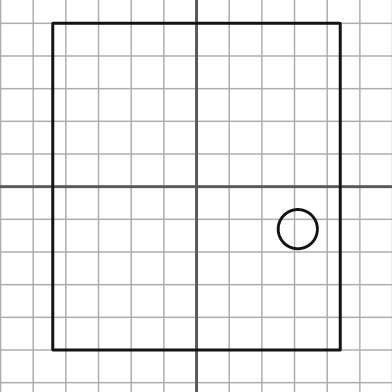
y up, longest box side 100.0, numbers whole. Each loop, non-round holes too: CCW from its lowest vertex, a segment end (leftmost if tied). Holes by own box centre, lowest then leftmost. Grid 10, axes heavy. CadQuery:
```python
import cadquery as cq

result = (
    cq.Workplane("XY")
    .moveTo(-44.0, -50.0)
    .lineTo(44.0, -50.0)
    .lineTo(44.0, 50.0)
    .lineTo(-44.0, 50.0)
    .close()
    .moveTo(31.0, -13.0)
    .circle(6.0)
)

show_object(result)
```